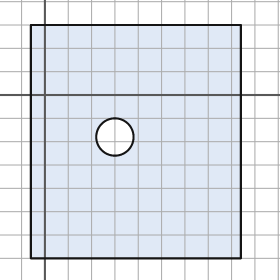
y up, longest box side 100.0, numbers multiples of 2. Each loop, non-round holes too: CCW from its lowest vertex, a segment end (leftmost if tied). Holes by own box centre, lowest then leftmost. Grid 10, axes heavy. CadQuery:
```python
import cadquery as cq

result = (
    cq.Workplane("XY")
    .moveTo(-6.0, -70.0)
    .lineTo(84.0, -70.0)
    .lineTo(84.0, 30.0)
    .lineTo(-6.0, 30.0)
    .close()
    .moveTo(30.0, -18.0)
    .circle(8.0)
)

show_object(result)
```